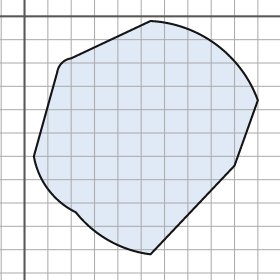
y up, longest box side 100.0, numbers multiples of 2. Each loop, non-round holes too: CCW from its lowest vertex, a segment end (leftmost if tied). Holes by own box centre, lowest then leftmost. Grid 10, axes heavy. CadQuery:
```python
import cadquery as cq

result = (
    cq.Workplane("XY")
    .moveTo(54.0, -102.0)
    .lineTo(90.0, -64.0)
    .lineTo(100.0, -36.0)
    .threePointArc((82.0, -12.0), (54.0, -2.0))
    .lineTo(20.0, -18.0)
    .threePointArc((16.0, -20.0), (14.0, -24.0))
    .lineTo(4.0, -60.0)
    .threePointArc((10.0, -74.0), (22.0, -84.0))
    .threePointArc((36.0, -96.0), (54.0, -102.0))
    .close()
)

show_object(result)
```